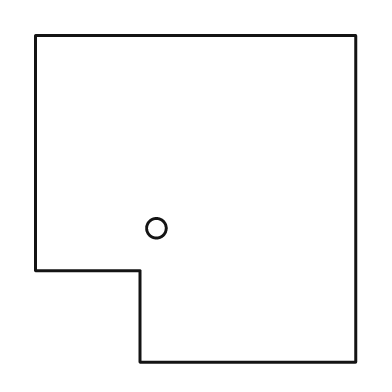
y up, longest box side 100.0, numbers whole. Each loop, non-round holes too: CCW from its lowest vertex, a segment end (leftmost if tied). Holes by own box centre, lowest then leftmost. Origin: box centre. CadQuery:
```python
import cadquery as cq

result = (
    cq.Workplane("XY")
    .moveTo(-17.0, -50.0)
    .lineTo(49.0, -50.0)
    .lineTo(49.0, 50.0)
    .lineTo(-49.0, 50.0)
    .lineTo(-49.0, -22.0)
    .lineTo(-17.0, -22.0)
    .close()
    .moveTo(-12.0, -9.0)
    .circle(3.0)
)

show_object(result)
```